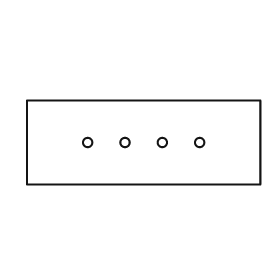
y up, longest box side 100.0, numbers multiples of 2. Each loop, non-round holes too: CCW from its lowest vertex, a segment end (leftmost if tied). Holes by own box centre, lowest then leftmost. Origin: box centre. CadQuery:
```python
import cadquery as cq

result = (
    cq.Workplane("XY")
    .moveTo(-50.0, -18.0)
    .lineTo(50.0, -18.0)
    .lineTo(50.0, 18.0)
    .lineTo(-50.0, 18.0)
    .close()
    .moveTo(-24.0, 0.0)
    .circle(2.0)
    .moveTo(-8.0, 0.0)
    .circle(2.0)
    .moveTo(8.0, 0.0)
    .circle(2.0)
    .moveTo(24.0, 0.0)
    .circle(2.0)
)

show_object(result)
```